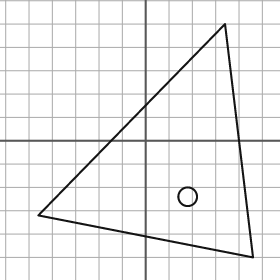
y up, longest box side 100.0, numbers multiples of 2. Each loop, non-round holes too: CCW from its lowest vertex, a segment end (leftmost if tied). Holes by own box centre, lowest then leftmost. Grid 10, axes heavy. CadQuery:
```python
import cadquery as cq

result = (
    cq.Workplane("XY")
    .moveTo(46.0, -50.0)
    .lineTo(34.0, 50.0)
    .lineTo(-46.0, -32.0)
    .close()
    .moveTo(18.0, -24.0)
    .circle(4.0)
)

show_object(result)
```